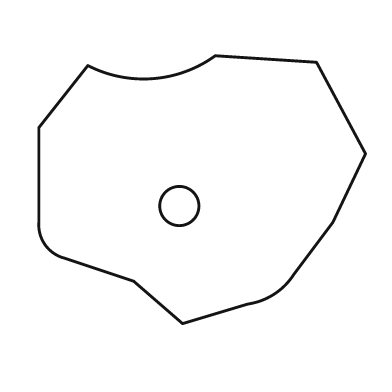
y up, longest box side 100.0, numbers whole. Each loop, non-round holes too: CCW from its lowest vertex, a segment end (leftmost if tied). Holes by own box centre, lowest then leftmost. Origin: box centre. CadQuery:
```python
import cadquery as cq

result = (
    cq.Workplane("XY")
    .moveTo(-6.0, -41.0)
    .lineTo(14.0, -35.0)
    .threePointArc((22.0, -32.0), (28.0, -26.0))
    .lineTo(40.0, -10.0)
    .lineTo(50.0, 11.0)
    .lineTo(35.0, 39.0)
    .lineTo(4.0, 41.0)
    .threePointArc((-15.0, 34.0), (-35.0, 38.0))
    .lineTo(-50.0, 19.0)
    .lineTo(-50.0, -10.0)
    .threePointArc((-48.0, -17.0), (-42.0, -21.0))
    .lineTo(-21.0, -28.0)
    .close()
    .moveTo(-7.0, -5.0)
    .circle(6.0)
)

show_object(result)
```